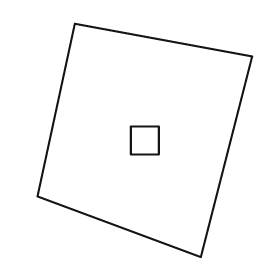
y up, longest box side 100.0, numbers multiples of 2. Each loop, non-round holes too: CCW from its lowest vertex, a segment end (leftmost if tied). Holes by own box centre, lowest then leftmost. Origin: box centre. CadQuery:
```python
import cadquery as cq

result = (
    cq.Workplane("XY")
    .moveTo(24.0, -50.0)
    .lineTo(46.0, 36.0)
    .lineTo(-30.0, 50.0)
    .lineTo(-46.0, -24.0)
    .close()
    .moveTo(-6.0, -6.0)
    .lineTo(6.0, -6.0)
    .lineTo(6.0, 6.0)
    .lineTo(-6.0, 6.0)
    .close()
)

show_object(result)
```